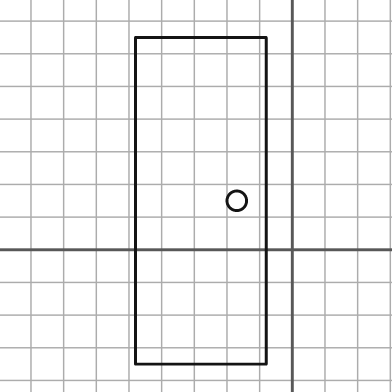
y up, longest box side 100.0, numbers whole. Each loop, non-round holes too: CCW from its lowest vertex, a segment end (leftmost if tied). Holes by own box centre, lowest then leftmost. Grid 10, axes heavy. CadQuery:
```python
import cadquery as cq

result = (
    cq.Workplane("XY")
    .moveTo(-48.0, -35.0)
    .lineTo(-8.0, -35.0)
    .lineTo(-8.0, 65.0)
    .lineTo(-48.0, 65.0)
    .close()
    .moveTo(-17.0, 15.0)
    .circle(3.0)
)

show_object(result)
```